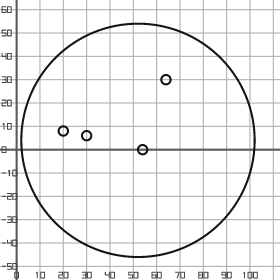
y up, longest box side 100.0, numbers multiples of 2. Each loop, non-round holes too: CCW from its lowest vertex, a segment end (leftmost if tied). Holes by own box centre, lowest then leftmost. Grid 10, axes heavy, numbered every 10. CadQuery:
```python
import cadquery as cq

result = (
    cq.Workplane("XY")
    .moveTo(52.0, 4.0)
    .circle(50.0)
    .moveTo(54.0, 0.0)
    .circle(2.0)
    .moveTo(30.0, 6.0)
    .circle(2.0)
    .moveTo(20.0, 8.0)
    .circle(2.0)
    .moveTo(64.0, 30.0)
    .circle(2.0)
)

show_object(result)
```